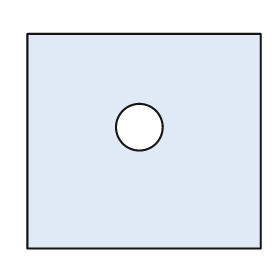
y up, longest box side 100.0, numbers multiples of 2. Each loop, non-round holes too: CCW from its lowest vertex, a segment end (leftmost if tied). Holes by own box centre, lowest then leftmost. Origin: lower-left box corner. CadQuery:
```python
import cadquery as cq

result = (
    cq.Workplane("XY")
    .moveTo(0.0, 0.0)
    .lineTo(100.0, 0.0)
    .lineTo(100.0, 92.0)
    .lineTo(0.0, 92.0)
    .close()
    .moveTo(48.0, 52.0)
    .circle(10.0)
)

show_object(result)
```